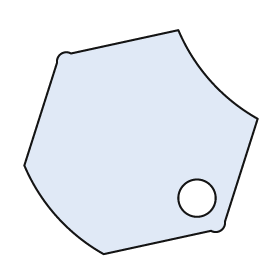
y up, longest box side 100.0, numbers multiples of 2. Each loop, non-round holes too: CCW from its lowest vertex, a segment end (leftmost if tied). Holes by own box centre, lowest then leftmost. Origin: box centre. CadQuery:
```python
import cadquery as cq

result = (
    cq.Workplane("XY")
    .moveTo(-16.0, -48.0)
    .lineTo(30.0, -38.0)
    .threePointArc((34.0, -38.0), (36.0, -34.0))
    .lineTo(50.0, 10.0)
    .threePointArc((30.0, 26.0), (16.0, 48.0))
    .lineTo(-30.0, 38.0)
    .threePointArc((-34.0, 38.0), (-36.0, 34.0))
    .lineTo(-50.0, -10.0)
    .threePointArc((-36.0, -32.0), (-16.0, -48.0))
    .close()
    .moveTo(24.0, -24.0)
    .circle(8.0)
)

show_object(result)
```